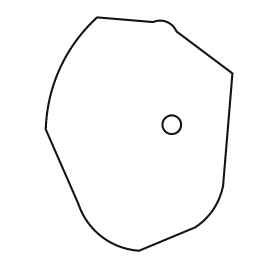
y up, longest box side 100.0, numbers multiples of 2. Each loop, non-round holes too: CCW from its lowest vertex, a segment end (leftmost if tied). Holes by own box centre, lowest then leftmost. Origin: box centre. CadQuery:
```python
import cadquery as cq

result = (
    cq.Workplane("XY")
    .moveTo(0.0, -50.0)
    .lineTo(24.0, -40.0)
    .threePointArc((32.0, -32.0), (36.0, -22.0))
    .lineTo(40.0, 26.0)
    .lineTo(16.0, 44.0)
    .threePointArc((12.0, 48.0), (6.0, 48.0))
    .lineTo(-18.0, 50.0)
    .threePointArc((-34.0, 28.0), (-40.0, 2.0))
    .lineTo(-26.0, -30.0)
    .threePointArc((-16.0, -44.0), (0.0, -50.0))
    .close()
    .moveTo(14.0, 4.0)
    .circle(4.0)
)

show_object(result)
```